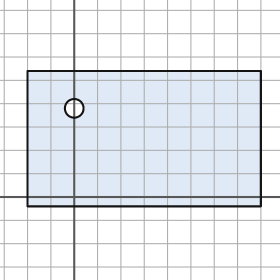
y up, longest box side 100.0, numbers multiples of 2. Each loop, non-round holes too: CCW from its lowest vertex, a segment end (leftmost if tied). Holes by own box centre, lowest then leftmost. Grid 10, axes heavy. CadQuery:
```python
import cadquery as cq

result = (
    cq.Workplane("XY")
    .moveTo(-20.0, -4.0)
    .lineTo(80.0, -4.0)
    .lineTo(80.0, 54.0)
    .lineTo(-20.0, 54.0)
    .close()
    .moveTo(0.0, 38.0)
    .circle(4.0)
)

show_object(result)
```